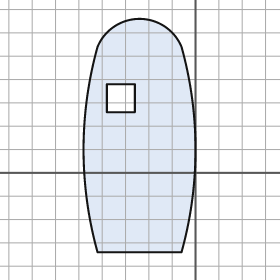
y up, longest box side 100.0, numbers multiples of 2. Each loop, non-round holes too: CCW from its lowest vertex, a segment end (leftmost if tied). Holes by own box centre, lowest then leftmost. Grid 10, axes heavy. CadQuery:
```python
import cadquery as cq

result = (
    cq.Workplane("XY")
    .moveTo(-42.0, -34.0)
    .lineTo(-6.0, -34.0)
    .threePointArc((0.0, 10.0), (-6.0, 54.0))
    .threePointArc((-24.0, 66.0), (-42.0, 54.0))
    .threePointArc((-48.0, 10.0), (-42.0, -34.0))
    .close()
    .moveTo(-38.0, 26.0)
    .lineTo(-26.0, 26.0)
    .lineTo(-26.0, 38.0)
    .lineTo(-38.0, 38.0)
    .close()
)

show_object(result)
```